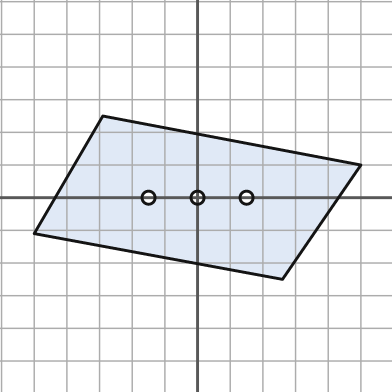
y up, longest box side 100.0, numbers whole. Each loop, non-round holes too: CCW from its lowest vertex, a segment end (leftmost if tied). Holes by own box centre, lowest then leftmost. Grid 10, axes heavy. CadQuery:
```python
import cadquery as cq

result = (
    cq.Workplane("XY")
    .moveTo(26.0, -25.0)
    .lineTo(50.0, 10.0)
    .lineTo(-29.0, 25.0)
    .lineTo(-50.0, -11.0)
    .close()
    .moveTo(-15.0, 0.0)
    .circle(2.0)
    .moveTo(0.0, 0.0)
    .circle(2.0)
    .moveTo(15.0, 0.0)
    .circle(2.0)
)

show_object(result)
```